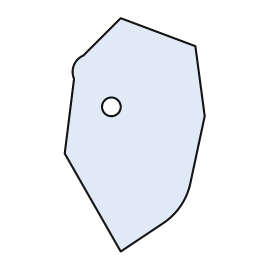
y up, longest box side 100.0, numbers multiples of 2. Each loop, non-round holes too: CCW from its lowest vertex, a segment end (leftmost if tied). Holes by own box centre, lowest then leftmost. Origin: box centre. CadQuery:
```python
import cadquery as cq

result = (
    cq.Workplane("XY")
    .moveTo(-6.0, -50.0)
    .lineTo(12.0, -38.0)
    .threePointArc((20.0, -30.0), (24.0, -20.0))
    .lineTo(30.0, 8.0)
    .lineTo(26.0, 38.0)
    .lineTo(-6.0, 50.0)
    .lineTo(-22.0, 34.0)
    .threePointArc((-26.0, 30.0), (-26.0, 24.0))
    .lineTo(-30.0, -8.0)
    .close()
    .moveTo(-10.0, 12.0)
    .circle(4.0)
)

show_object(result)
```